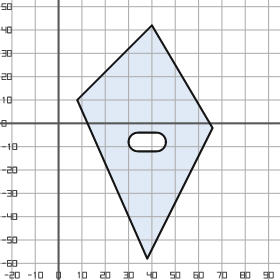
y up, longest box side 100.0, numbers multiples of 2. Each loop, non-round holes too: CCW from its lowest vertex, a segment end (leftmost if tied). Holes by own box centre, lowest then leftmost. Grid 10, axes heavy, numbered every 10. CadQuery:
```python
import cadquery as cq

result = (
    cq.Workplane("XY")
    .moveTo(38.0, -58.0)
    .lineTo(66.0, -2.0)
    .lineTo(40.0, 42.0)
    .lineTo(8.0, 10.0)
    .close()
    .moveTo(34.0, -12.0)
    .lineTo(42.0, -12.0)
    .threePointArc((46.0, -8.0), (42.0, -4.0))
    .lineTo(34.0, -4.0)
    .threePointArc((30.0, -8.0), (34.0, -12.0))
    .close()
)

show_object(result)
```